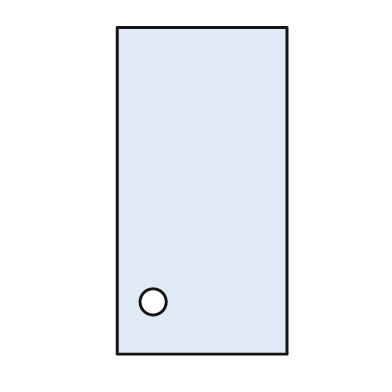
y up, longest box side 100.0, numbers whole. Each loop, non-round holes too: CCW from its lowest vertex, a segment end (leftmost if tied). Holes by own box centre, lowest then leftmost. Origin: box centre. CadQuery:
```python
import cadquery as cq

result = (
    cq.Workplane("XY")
    .moveTo(-26.0, -50.0)
    .lineTo(26.0, -50.0)
    .lineTo(26.0, 50.0)
    .lineTo(-26.0, 50.0)
    .close()
    .moveTo(-15.0, -34.0)
    .circle(4.0)
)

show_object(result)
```